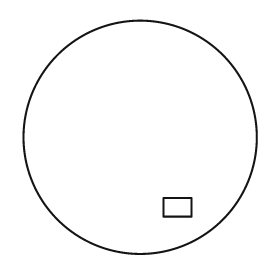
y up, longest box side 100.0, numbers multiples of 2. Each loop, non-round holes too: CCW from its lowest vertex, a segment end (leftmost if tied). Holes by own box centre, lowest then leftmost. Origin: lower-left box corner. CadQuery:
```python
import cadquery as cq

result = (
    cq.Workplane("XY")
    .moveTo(50.0, 50.0)
    .circle(50.0)
    .moveTo(60.0, 16.0)
    .lineTo(72.0, 16.0)
    .lineTo(72.0, 24.0)
    .lineTo(60.0, 24.0)
    .close()
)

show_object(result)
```